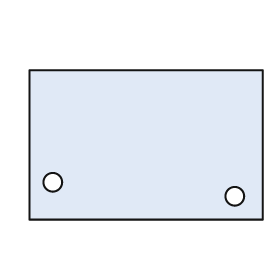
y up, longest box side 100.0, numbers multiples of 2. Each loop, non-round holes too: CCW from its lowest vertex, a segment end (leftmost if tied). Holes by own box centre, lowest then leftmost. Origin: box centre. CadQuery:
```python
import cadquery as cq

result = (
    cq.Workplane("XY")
    .moveTo(-50.0, -32.0)
    .lineTo(50.0, -32.0)
    .lineTo(50.0, 32.0)
    .lineTo(-50.0, 32.0)
    .close()
    .moveTo(38.0, -22.0)
    .circle(4.0)
    .moveTo(-40.0, -16.0)
    .circle(4.0)
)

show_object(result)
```